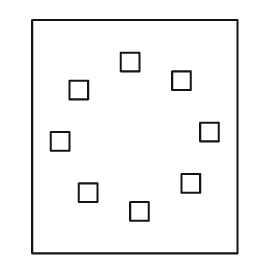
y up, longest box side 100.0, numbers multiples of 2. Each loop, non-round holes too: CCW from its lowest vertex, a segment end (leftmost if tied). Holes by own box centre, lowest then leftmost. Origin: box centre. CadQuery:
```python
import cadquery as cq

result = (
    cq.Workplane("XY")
    .moveTo(-44.0, -50.0)
    .lineTo(44.0, -50.0)
    .lineTo(44.0, 50.0)
    .lineTo(-44.0, 50.0)
    .close()
    .moveTo(-2.0, -36.0)
    .lineTo(6.0, -36.0)
    .lineTo(6.0, -28.0)
    .lineTo(-2.0, -28.0)
    .close()
    .moveTo(-24.0, -28.0)
    .lineTo(-16.0, -28.0)
    .lineTo(-16.0, -20.0)
    .lineTo(-24.0, -20.0)
    .close()
    .moveTo(20.0, -24.0)
    .lineTo(28.0, -24.0)
    .lineTo(28.0, -16.0)
    .lineTo(20.0, -16.0)
    .close()
    .moveTo(-36.0, -6.0)
    .lineTo(-28.0, -6.0)
    .lineTo(-28.0, 2.0)
    .lineTo(-36.0, 2.0)
    .close()
    .moveTo(28.0, -2.0)
    .lineTo(36.0, -2.0)
    .lineTo(36.0, 6.0)
    .lineTo(28.0, 6.0)
    .close()
    .moveTo(-28.0, 16.0)
    .lineTo(-20.0, 16.0)
    .lineTo(-20.0, 24.0)
    .lineTo(-28.0, 24.0)
    .close()
    .moveTo(16.0, 20.0)
    .lineTo(24.0, 20.0)
    .lineTo(24.0, 28.0)
    .lineTo(16.0, 28.0)
    .close()
    .moveTo(-6.0, 28.0)
    .lineTo(2.0, 28.0)
    .lineTo(2.0, 36.0)
    .lineTo(-6.0, 36.0)
    .close()
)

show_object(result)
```